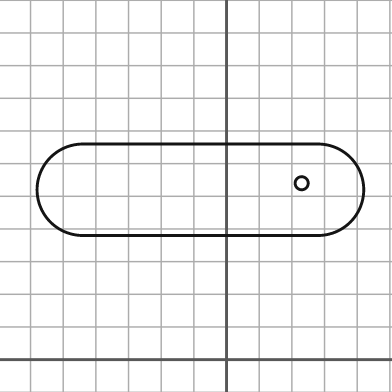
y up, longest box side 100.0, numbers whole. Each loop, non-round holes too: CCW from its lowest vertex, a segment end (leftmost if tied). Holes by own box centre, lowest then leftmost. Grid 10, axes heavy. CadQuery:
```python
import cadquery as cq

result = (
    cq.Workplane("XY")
    .moveTo(-44.0, 38.0)
    .lineTo(28.0, 38.0)
    .threePointArc((42.0, 52.0), (28.0, 66.0))
    .lineTo(-44.0, 66.0)
    .threePointArc((-58.0, 52.0), (-44.0, 38.0))
    .close()
    .moveTo(23.0, 54.0)
    .circle(2.0)
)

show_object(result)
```